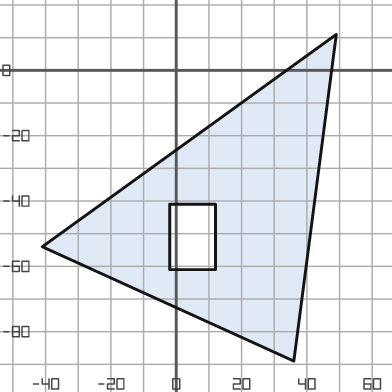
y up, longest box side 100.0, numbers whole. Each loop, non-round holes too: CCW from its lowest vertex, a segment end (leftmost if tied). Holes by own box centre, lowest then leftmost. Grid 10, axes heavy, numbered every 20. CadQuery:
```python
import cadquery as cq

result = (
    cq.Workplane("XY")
    .moveTo(36.0, -89.0)
    .lineTo(49.0, 11.0)
    .lineTo(-41.0, -54.0)
    .close()
    .moveTo(-2.0, -61.0)
    .lineTo(12.0, -61.0)
    .lineTo(12.0, -41.0)
    .lineTo(-2.0, -41.0)
    .close()
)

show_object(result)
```